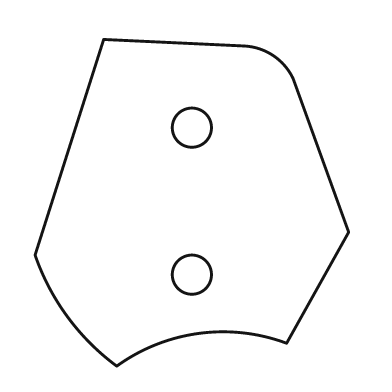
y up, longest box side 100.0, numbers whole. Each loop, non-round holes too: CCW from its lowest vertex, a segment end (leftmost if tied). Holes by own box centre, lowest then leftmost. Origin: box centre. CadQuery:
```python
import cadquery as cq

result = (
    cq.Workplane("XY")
    .moveTo(-23.0, -50.0)
    .threePointArc((2.0, -40.0), (29.0, -43.0))
    .lineTo(48.0, -9.0)
    .lineTo(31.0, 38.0)
    .threePointArc((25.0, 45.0), (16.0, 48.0))
    .lineTo(-27.0, 50.0)
    .lineTo(-48.0, -16.0)
    .threePointArc((-38.0, -35.0), (-23.0, -50.0))
    .close()
    .moveTo(0.0, -22.0)
    .circle(6.0)
    .moveTo(0.0, 23.0)
    .circle(6.0)
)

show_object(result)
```